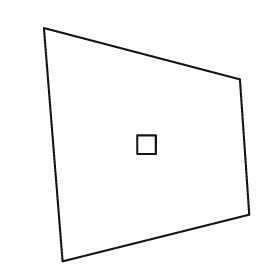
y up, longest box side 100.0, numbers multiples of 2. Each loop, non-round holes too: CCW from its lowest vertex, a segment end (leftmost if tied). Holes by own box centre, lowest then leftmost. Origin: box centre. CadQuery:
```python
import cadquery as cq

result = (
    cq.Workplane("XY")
    .moveTo(-36.0, -50.0)
    .lineTo(44.0, -30.0)
    .lineTo(40.0, 28.0)
    .lineTo(-44.0, 50.0)
    .close()
    .moveTo(-4.0, -4.0)
    .lineTo(4.0, -4.0)
    .lineTo(4.0, 4.0)
    .lineTo(-4.0, 4.0)
    .close()
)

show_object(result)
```